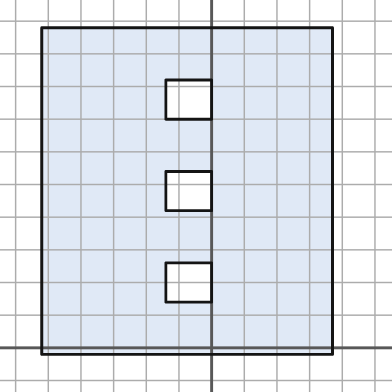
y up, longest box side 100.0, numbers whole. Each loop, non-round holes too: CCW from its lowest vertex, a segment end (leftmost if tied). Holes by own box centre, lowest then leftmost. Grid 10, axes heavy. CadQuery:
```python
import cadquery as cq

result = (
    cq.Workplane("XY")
    .moveTo(-52.0, -2.0)
    .lineTo(37.0, -2.0)
    .lineTo(37.0, 98.0)
    .lineTo(-52.0, 98.0)
    .close()
    .moveTo(-14.0, 14.0)
    .lineTo(0.0, 14.0)
    .lineTo(0.0, 26.0)
    .lineTo(-14.0, 26.0)
    .close()
    .moveTo(-14.0, 42.0)
    .lineTo(0.0, 42.0)
    .lineTo(0.0, 54.0)
    .lineTo(-14.0, 54.0)
    .close()
    .moveTo(-14.0, 70.0)
    .lineTo(0.0, 70.0)
    .lineTo(0.0, 82.0)
    .lineTo(-14.0, 82.0)
    .close()
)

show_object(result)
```